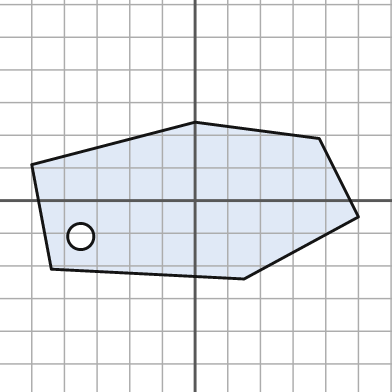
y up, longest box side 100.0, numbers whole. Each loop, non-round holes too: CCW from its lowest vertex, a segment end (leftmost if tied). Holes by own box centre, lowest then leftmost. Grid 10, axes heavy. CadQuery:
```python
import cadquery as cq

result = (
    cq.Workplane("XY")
    .moveTo(15.0, -24.0)
    .lineTo(50.0, -5.0)
    .lineTo(38.0, 19.0)
    .lineTo(0.0, 24.0)
    .lineTo(-50.0, 11.0)
    .lineTo(-44.0, -21.0)
    .close()
    .moveTo(-35.0, -11.0)
    .circle(4.0)
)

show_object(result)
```